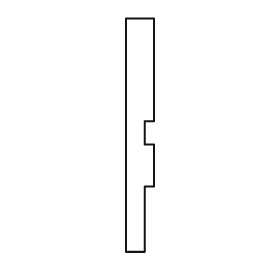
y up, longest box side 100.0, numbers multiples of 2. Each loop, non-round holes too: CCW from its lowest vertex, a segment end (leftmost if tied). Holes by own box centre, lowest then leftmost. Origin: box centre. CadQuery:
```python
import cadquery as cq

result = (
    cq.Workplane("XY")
    .moveTo(-6.0, -50.0)
    .lineTo(2.0, -50.0)
    .lineTo(2.0, -22.0)
    .lineTo(6.0, -22.0)
    .lineTo(6.0, -4.0)
    .lineTo(2.0, -4.0)
    .lineTo(2.0, 6.0)
    .lineTo(6.0, 6.0)
    .lineTo(6.0, 50.0)
    .lineTo(-6.0, 50.0)
    .close()
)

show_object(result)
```